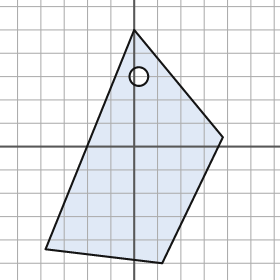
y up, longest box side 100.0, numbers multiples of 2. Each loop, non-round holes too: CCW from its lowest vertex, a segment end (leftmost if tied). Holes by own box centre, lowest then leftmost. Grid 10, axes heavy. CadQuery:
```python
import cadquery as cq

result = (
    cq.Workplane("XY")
    .moveTo(12.0, -50.0)
    .lineTo(38.0, 4.0)
    .lineTo(0.0, 50.0)
    .lineTo(-38.0, -44.0)
    .close()
    .moveTo(2.0, 30.0)
    .circle(4.0)
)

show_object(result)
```